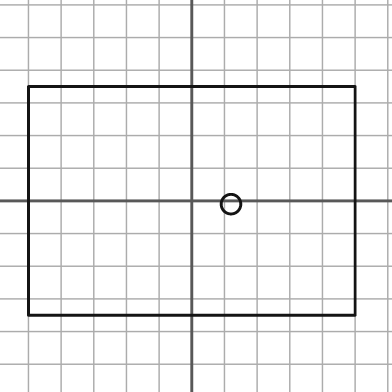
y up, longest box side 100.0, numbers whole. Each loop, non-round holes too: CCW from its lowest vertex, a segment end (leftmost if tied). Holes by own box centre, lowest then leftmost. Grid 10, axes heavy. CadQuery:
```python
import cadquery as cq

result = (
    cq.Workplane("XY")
    .moveTo(-50.0, -35.0)
    .lineTo(50.0, -35.0)
    .lineTo(50.0, 35.0)
    .lineTo(-50.0, 35.0)
    .close()
    .moveTo(12.0, -1.0)
    .circle(3.0)
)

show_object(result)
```